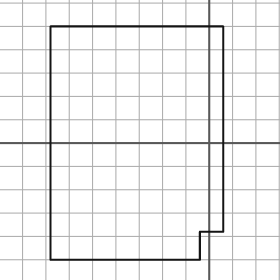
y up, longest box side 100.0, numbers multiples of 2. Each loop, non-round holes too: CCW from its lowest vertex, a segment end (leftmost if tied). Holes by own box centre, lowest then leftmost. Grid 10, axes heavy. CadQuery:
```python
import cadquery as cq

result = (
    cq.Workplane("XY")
    .moveTo(-68.0, -50.0)
    .lineTo(-4.0, -50.0)
    .lineTo(-4.0, -38.0)
    .lineTo(6.0, -38.0)
    .lineTo(6.0, 50.0)
    .lineTo(-68.0, 50.0)
    .close()
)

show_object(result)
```